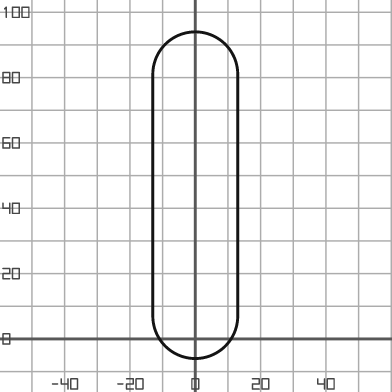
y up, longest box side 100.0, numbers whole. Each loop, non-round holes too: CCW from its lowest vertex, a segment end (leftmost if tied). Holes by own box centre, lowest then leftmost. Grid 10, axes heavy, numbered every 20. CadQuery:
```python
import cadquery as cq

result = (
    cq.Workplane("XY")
    .moveTo(-13.0, 7.0)
    .threePointArc((0.0, -6.0), (13.0, 7.0))
    .lineTo(13.0, 81.0)
    .threePointArc((0.0, 94.0), (-13.0, 81.0))
    .close()
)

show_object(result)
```